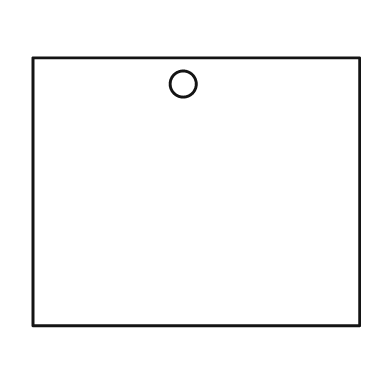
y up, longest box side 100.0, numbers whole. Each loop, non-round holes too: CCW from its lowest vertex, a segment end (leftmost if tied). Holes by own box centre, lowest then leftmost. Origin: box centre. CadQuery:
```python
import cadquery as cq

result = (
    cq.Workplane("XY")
    .moveTo(-50.0, -41.0)
    .lineTo(50.0, -41.0)
    .lineTo(50.0, 41.0)
    .lineTo(-50.0, 41.0)
    .close()
    .moveTo(-4.0, 33.0)
    .circle(4.0)
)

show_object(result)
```